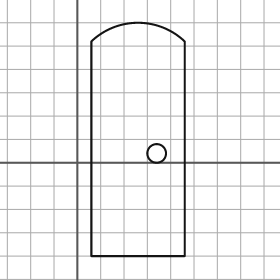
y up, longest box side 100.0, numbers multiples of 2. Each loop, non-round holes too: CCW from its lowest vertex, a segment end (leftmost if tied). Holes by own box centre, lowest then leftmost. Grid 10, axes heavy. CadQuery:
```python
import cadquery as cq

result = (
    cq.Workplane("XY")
    .moveTo(6.0, -40.0)
    .lineTo(46.0, -40.0)
    .lineTo(46.0, 52.0)
    .threePointArc((26.0, 60.0), (6.0, 52.0))
    .close()
    .moveTo(34.0, 4.0)
    .circle(4.0)
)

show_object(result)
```